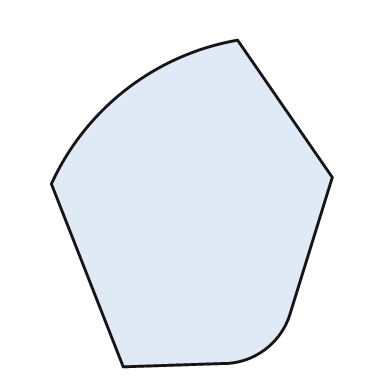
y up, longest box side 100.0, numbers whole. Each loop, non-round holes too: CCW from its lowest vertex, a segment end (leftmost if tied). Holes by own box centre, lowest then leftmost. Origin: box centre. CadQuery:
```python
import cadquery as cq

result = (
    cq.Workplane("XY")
    .moveTo(-21.0, -50.0)
    .lineTo(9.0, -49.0)
    .threePointArc((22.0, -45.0), (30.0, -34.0))
    .lineTo(43.0, 8.0)
    .lineTo(14.0, 50.0)
    .threePointArc((-20.0, 35.0), (-43.0, 6.0))
    .close()
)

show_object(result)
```